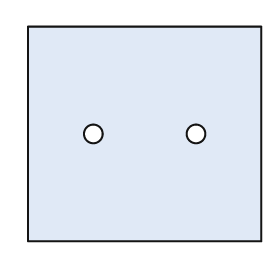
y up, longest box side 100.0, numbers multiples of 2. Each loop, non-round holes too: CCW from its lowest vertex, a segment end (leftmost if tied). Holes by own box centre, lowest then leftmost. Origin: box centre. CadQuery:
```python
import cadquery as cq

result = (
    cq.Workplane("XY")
    .moveTo(-50.0, -46.0)
    .lineTo(50.0, -46.0)
    .lineTo(50.0, 46.0)
    .lineTo(-50.0, 46.0)
    .close()
    .moveTo(-22.0, 0.0)
    .circle(4.0)
    .moveTo(22.0, 0.0)
    .circle(4.0)
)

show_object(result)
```